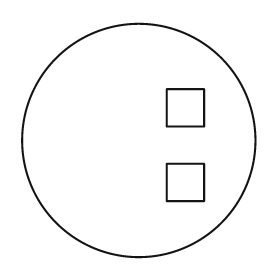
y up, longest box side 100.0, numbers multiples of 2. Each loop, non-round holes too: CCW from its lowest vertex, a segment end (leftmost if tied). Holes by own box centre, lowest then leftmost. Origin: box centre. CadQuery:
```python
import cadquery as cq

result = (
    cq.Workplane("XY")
    .moveTo(0.0, 0.0)
    .circle(50.0)
    .moveTo(12.0, -26.0)
    .lineTo(28.0, -26.0)
    .lineTo(28.0, -10.0)
    .lineTo(12.0, -10.0)
    .close()
    .moveTo(12.0, 6.0)
    .lineTo(28.0, 6.0)
    .lineTo(28.0, 22.0)
    .lineTo(12.0, 22.0)
    .close()
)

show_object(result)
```